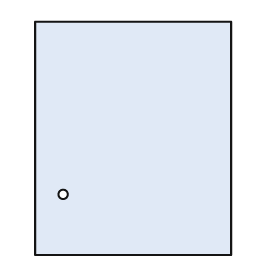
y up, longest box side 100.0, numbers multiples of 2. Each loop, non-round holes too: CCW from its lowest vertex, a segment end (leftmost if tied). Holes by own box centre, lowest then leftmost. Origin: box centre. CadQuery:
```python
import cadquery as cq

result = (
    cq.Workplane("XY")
    .moveTo(-42.0, -50.0)
    .lineTo(42.0, -50.0)
    .lineTo(42.0, 50.0)
    .lineTo(-42.0, 50.0)
    .close()
    .moveTo(-30.0, -24.0)
    .circle(2.0)
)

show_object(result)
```